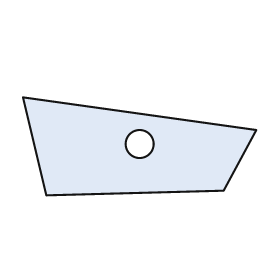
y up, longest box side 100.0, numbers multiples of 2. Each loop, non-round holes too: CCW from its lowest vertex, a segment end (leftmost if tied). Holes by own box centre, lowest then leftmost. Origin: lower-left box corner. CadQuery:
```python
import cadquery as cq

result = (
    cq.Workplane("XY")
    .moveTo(10.0, 0.0)
    .lineTo(86.0, 2.0)
    .lineTo(100.0, 28.0)
    .lineTo(0.0, 42.0)
    .close()
    .moveTo(50.0, 22.0)
    .circle(6.0)
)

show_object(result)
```